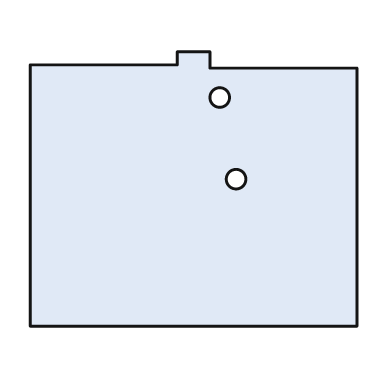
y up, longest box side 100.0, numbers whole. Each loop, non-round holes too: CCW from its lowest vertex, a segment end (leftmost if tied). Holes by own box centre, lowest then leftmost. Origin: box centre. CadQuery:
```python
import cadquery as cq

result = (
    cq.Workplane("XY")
    .moveTo(-50.0, -42.0)
    .lineTo(50.0, -42.0)
    .lineTo(50.0, 37.0)
    .lineTo(5.0, 37.0)
    .lineTo(5.0, 42.0)
    .lineTo(-5.0, 42.0)
    .lineTo(-5.0, 38.0)
    .lineTo(-50.0, 38.0)
    .close()
    .moveTo(13.0, 3.0)
    .circle(3.0)
    .moveTo(8.0, 28.0)
    .circle(3.0)
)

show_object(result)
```